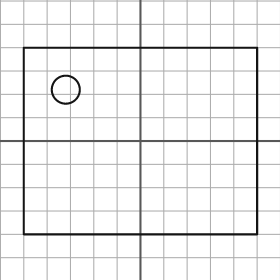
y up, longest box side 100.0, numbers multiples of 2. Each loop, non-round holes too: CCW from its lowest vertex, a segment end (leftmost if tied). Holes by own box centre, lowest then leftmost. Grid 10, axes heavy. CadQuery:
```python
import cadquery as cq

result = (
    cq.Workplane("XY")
    .moveTo(-50.0, -40.0)
    .lineTo(50.0, -40.0)
    .lineTo(50.0, 40.0)
    .lineTo(-50.0, 40.0)
    .close()
    .moveTo(-32.0, 22.0)
    .circle(6.0)
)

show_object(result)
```